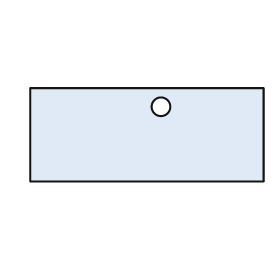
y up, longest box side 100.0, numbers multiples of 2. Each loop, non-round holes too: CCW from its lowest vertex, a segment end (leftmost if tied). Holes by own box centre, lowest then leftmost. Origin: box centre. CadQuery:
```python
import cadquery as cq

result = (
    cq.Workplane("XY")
    .moveTo(-50.0, -20.0)
    .lineTo(50.0, -20.0)
    .lineTo(50.0, 20.0)
    .lineTo(-50.0, 20.0)
    .close()
    .moveTo(6.0, 12.0)
    .circle(4.0)
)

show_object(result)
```